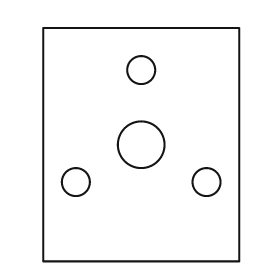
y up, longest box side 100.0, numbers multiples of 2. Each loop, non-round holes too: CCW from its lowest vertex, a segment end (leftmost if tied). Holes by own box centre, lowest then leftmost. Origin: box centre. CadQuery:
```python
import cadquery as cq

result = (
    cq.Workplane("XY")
    .moveTo(-42.0, -50.0)
    .lineTo(42.0, -50.0)
    .lineTo(42.0, 50.0)
    .lineTo(-42.0, 50.0)
    .close()
    .moveTo(-28.0, -16.0)
    .circle(6.0)
    .moveTo(28.0, -16.0)
    .circle(6.0)
    .moveTo(0.0, 0.0)
    .circle(10.0)
    .moveTo(0.0, 32.0)
    .circle(6.0)
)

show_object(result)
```